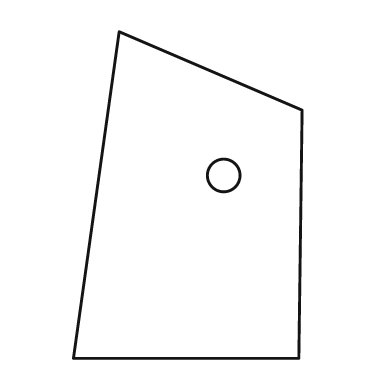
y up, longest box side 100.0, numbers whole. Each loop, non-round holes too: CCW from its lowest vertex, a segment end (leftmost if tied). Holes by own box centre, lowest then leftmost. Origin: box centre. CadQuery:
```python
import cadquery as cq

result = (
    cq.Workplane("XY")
    .moveTo(-35.0, -50.0)
    .lineTo(34.0, -50.0)
    .lineTo(35.0, 26.0)
    .lineTo(-21.0, 50.0)
    .close()
    .moveTo(11.0, 6.0)
    .circle(5.0)
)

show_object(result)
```